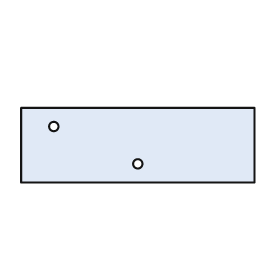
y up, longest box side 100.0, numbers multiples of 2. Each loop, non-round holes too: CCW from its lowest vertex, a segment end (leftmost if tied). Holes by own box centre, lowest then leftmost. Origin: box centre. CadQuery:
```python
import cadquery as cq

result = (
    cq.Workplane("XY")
    .moveTo(-50.0, -16.0)
    .lineTo(50.0, -16.0)
    .lineTo(50.0, 16.0)
    .lineTo(-50.0, 16.0)
    .close()
    .moveTo(0.0, -8.0)
    .circle(2.0)
    .moveTo(-36.0, 8.0)
    .circle(2.0)
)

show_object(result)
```